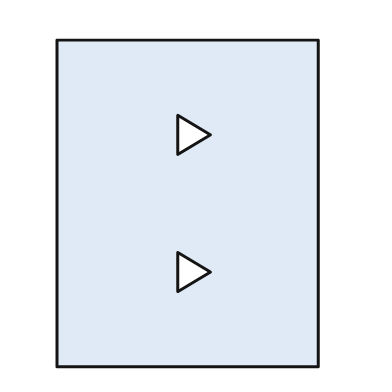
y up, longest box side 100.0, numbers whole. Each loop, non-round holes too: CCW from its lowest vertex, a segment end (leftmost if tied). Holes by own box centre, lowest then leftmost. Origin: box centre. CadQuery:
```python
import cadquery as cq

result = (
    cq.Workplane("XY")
    .moveTo(-40.0, -50.0)
    .lineTo(40.0, -50.0)
    .lineTo(40.0, 50.0)
    .lineTo(-40.0, 50.0)
    .close()
    .moveTo(-3.0, -27.0)
    .lineTo(7.0, -21.0)
    .lineTo(-3.0, -15.0)
    .close()
    .moveTo(-3.0, 15.0)
    .lineTo(7.0, 21.0)
    .lineTo(-3.0, 27.0)
    .close()
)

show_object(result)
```